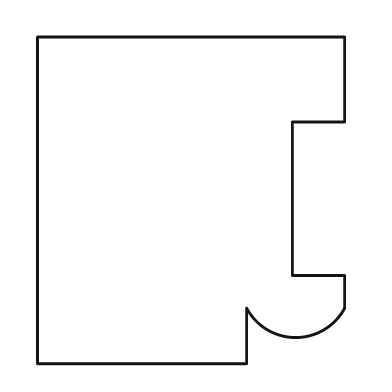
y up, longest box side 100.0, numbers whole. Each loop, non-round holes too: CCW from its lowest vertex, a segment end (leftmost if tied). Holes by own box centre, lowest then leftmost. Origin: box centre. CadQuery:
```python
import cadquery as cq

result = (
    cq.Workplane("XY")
    .moveTo(-47.0, -50.0)
    .lineTo(17.0, -50.0)
    .lineTo(17.0, -33.0)
    .threePointArc((32.0, -42.0), (47.0, -33.0))
    .lineTo(47.0, -23.0)
    .lineTo(31.0, -23.0)
    .lineTo(31.0, 24.0)
    .lineTo(47.0, 24.0)
    .lineTo(47.0, 50.0)
    .lineTo(-47.0, 50.0)
    .close()
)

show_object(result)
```